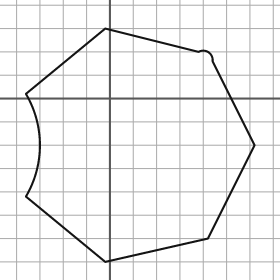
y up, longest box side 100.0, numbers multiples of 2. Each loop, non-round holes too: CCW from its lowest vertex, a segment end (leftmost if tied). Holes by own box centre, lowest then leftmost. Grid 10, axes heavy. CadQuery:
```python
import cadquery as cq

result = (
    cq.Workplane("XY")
    .moveTo(-2.0, -70.0)
    .lineTo(42.0, -60.0)
    .lineTo(62.0, -20.0)
    .lineTo(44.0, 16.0)
    .threePointArc((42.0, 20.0), (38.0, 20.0))
    .lineTo(-2.0, 30.0)
    .lineTo(-36.0, 2.0)
    .threePointArc((-30.0, -20.0), (-36.0, -42.0))
    .close()
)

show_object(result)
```